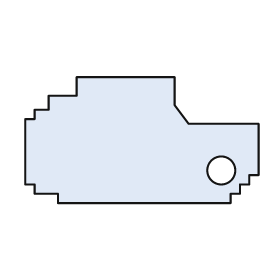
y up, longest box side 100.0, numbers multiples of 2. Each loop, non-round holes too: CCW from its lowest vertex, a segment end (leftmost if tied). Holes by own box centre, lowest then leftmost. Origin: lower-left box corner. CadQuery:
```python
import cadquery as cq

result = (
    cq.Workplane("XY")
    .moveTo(14.0, 0.0)
    .lineTo(88.0, 0.0)
    .lineTo(88.0, 4.0)
    .lineTo(92.0, 4.0)
    .lineTo(92.0, 8.0)
    .lineTo(96.0, 8.0)
    .lineTo(96.0, 12.0)
    .lineTo(100.0, 12.0)
    .lineTo(100.0, 34.0)
    .lineTo(70.0, 34.0)
    .lineTo(64.0, 42.0)
    .lineTo(64.0, 54.0)
    .lineTo(22.0, 54.0)
    .lineTo(22.0, 46.0)
    .lineTo(10.0, 46.0)
    .lineTo(10.0, 40.0)
    .lineTo(4.0, 40.0)
    .lineTo(4.0, 36.0)
    .lineTo(0.0, 36.0)
    .lineTo(0.0, 8.0)
    .lineTo(4.0, 8.0)
    .lineTo(4.0, 4.0)
    .lineTo(14.0, 4.0)
    .close()
    .moveTo(84.0, 14.0)
    .circle(6.0)
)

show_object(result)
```